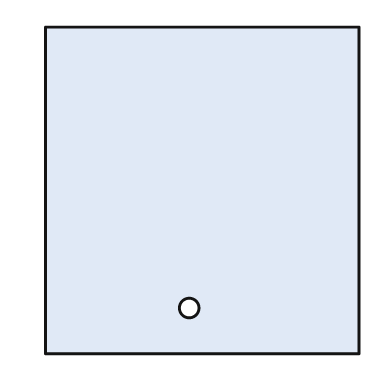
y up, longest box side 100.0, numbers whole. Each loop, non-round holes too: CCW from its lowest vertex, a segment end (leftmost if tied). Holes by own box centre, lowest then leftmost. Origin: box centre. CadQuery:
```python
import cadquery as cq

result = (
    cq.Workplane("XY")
    .moveTo(-48.0, -50.0)
    .lineTo(48.0, -50.0)
    .lineTo(48.0, 50.0)
    .lineTo(-48.0, 50.0)
    .close()
    .moveTo(-4.0, -36.0)
    .circle(3.0)
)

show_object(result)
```